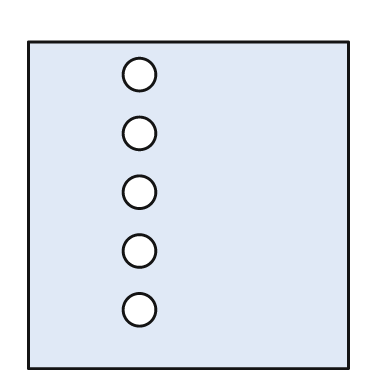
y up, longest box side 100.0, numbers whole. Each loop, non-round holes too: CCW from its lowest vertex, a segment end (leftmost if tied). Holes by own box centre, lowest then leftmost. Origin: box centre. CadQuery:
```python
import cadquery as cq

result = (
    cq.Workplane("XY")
    .moveTo(-49.0, -50.0)
    .lineTo(49.0, -50.0)
    .lineTo(49.0, 50.0)
    .lineTo(-49.0, 50.0)
    .close()
    .moveTo(-15.0, -32.0)
    .circle(5.0)
    .moveTo(-15.0, -14.0)
    .circle(5.0)
    .moveTo(-15.0, 4.0)
    .circle(5.0)
    .moveTo(-15.0, 22.0)
    .circle(5.0)
    .moveTo(-15.0, 40.0)
    .circle(5.0)
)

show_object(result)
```